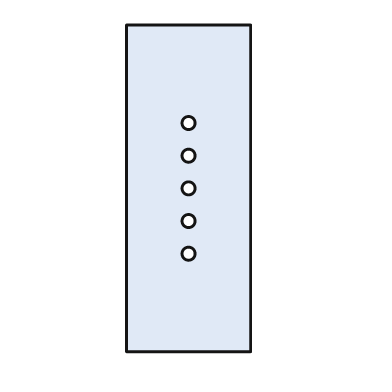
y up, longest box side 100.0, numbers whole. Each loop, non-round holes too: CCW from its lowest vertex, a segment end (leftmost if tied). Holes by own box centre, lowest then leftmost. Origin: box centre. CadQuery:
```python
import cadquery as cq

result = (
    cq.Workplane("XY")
    .moveTo(-19.0, -50.0)
    .lineTo(19.0, -50.0)
    .lineTo(19.0, 50.0)
    .lineTo(-19.0, 50.0)
    .close()
    .moveTo(0.0, -20.0)
    .circle(2.0)
    .moveTo(0.0, -10.0)
    .circle(2.0)
    .moveTo(0.0, 0.0)
    .circle(2.0)
    .moveTo(0.0, 10.0)
    .circle(2.0)
    .moveTo(0.0, 20.0)
    .circle(2.0)
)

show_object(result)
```